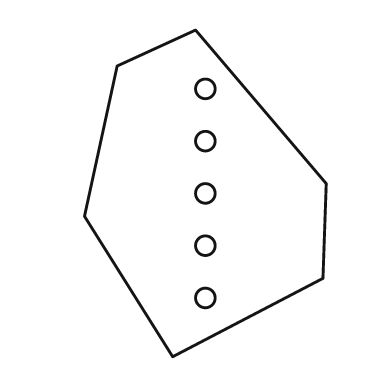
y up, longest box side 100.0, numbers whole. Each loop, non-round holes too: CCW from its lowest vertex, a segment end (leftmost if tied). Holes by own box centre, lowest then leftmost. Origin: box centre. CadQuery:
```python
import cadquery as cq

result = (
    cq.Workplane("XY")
    .moveTo(-10.0, -50.0)
    .lineTo(36.0, -26.0)
    .lineTo(37.0, 3.0)
    .lineTo(-3.0, 50.0)
    .lineTo(-27.0, 39.0)
    .lineTo(-37.0, -7.0)
    .close()
    .moveTo(0.0, -32.0)
    .circle(3.0)
    .moveTo(0.0, -16.0)
    .circle(3.0)
    .moveTo(0.0, 0.0)
    .circle(3.0)
    .moveTo(0.0, 16.0)
    .circle(3.0)
    .moveTo(0.0, 32.0)
    .circle(3.0)
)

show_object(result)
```